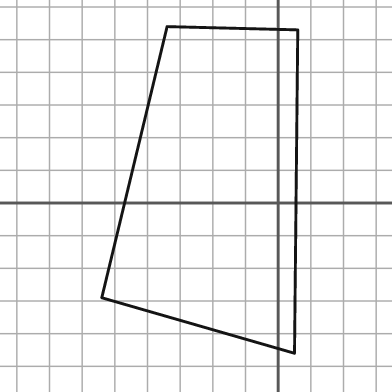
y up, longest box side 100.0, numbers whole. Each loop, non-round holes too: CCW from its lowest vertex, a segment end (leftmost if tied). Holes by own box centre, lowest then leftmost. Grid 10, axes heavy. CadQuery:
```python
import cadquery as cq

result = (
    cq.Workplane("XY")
    .moveTo(5.0, -46.0)
    .lineTo(6.0, 53.0)
    .lineTo(-34.0, 54.0)
    .lineTo(-54.0, -29.0)
    .close()
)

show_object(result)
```